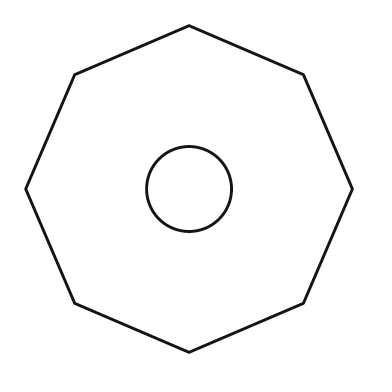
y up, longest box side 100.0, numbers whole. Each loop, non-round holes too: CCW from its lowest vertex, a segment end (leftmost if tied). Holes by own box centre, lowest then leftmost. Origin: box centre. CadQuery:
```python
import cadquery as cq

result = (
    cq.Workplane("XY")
    .moveTo(0.0, -50.0)
    .lineTo(35.0, -35.0)
    .lineTo(50.0, 0.0)
    .lineTo(35.0, 35.0)
    .lineTo(0.0, 50.0)
    .lineTo(-35.0, 35.0)
    .lineTo(-50.0, 0.0)
    .lineTo(-35.0, -35.0)
    .close()
    .moveTo(0.0, 0.0)
    .circle(13.0)
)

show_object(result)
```